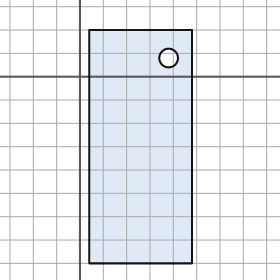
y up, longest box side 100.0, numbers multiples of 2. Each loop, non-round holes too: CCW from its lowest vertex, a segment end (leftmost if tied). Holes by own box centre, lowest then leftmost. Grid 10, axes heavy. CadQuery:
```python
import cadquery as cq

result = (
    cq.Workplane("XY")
    .moveTo(4.0, -80.0)
    .lineTo(48.0, -80.0)
    .lineTo(48.0, 20.0)
    .lineTo(4.0, 20.0)
    .close()
    .moveTo(38.0, 8.0)
    .circle(4.0)
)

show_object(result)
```